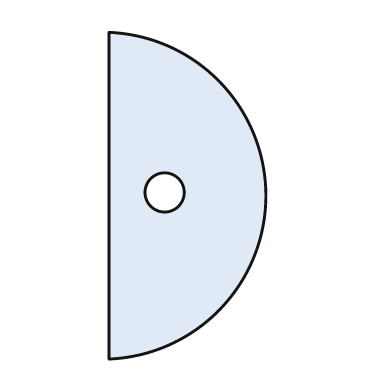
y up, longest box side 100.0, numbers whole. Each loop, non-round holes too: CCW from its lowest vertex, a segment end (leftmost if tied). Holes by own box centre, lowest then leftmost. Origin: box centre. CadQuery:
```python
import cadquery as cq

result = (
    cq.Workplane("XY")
    .moveTo(-24.0, -50.0)
    .threePointArc((24.0, 0.0), (-24.0, 50.0))
    .close()
    .moveTo(-7.0, 1.0)
    .circle(6.0)
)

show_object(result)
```